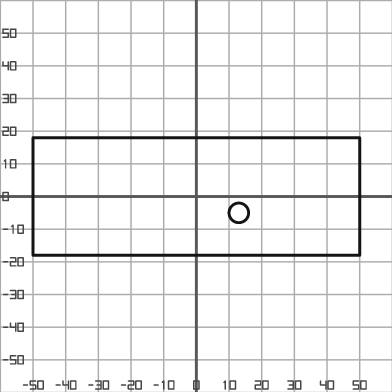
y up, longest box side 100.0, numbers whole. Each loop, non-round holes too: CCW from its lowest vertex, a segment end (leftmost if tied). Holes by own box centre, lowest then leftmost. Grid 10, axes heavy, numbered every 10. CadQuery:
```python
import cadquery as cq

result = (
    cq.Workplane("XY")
    .moveTo(-50.0, -18.0)
    .lineTo(50.0, -18.0)
    .lineTo(50.0, 18.0)
    .lineTo(-50.0, 18.0)
    .close()
    .moveTo(13.0, -5.0)
    .circle(3.0)
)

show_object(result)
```